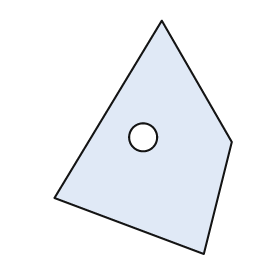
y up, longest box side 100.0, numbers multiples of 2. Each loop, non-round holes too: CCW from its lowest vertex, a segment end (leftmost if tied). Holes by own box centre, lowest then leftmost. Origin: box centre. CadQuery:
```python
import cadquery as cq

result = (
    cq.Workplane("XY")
    .moveTo(26.0, -50.0)
    .lineTo(38.0, -2.0)
    .lineTo(8.0, 50.0)
    .lineTo(-38.0, -26.0)
    .close()
    .moveTo(0.0, 0.0)
    .circle(6.0)
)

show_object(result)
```